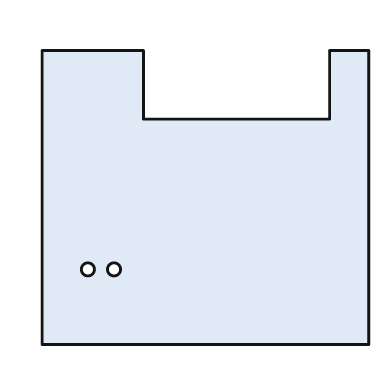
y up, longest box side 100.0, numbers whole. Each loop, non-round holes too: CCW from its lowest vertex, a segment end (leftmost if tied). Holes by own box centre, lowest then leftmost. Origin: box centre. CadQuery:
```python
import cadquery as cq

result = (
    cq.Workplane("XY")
    .moveTo(-50.0, -45.0)
    .lineTo(50.0, -45.0)
    .lineTo(50.0, 45.0)
    .lineTo(38.0, 45.0)
    .lineTo(38.0, 24.0)
    .lineTo(-19.0, 24.0)
    .lineTo(-19.0, 45.0)
    .lineTo(-50.0, 45.0)
    .close()
    .moveTo(-36.0, -22.0)
    .circle(2.0)
    .moveTo(-28.0, -22.0)
    .circle(2.0)
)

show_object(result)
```